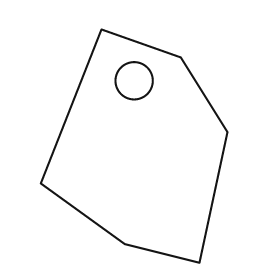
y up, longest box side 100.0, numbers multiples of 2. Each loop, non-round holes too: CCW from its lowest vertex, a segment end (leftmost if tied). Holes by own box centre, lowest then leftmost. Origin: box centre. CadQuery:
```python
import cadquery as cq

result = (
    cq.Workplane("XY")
    .moveTo(28.0, -50.0)
    .lineTo(40.0, 6.0)
    .lineTo(20.0, 38.0)
    .lineTo(-14.0, 50.0)
    .lineTo(-40.0, -16.0)
    .lineTo(-4.0, -42.0)
    .close()
    .moveTo(0.0, 28.0)
    .circle(8.0)
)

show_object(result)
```